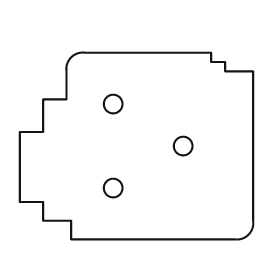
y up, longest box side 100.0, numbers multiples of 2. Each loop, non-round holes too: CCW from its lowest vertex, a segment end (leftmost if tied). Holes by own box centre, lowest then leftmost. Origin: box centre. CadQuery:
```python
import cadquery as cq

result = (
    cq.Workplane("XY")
    .moveTo(-28.0, -40.0)
    .lineTo(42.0, -40.0)
    .threePointArc((48.0, -38.0), (50.0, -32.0))
    .lineTo(50.0, 32.0)
    .lineTo(38.0, 32.0)
    .lineTo(38.0, 36.0)
    .lineTo(32.0, 36.0)
    .lineTo(32.0, 40.0)
    .lineTo(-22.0, 40.0)
    .threePointArc((-28.0, 38.0), (-30.0, 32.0))
    .lineTo(-30.0, 20.0)
    .lineTo(-40.0, 20.0)
    .lineTo(-40.0, 6.0)
    .lineTo(-50.0, 6.0)
    .lineTo(-50.0, -24.0)
    .lineTo(-40.0, -24.0)
    .lineTo(-40.0, -32.0)
    .lineTo(-28.0, -32.0)
    .close()
    .moveTo(-10.0, -18.0)
    .circle(4.0)
    .moveTo(20.0, 0.0)
    .circle(4.0)
    .moveTo(-10.0, 18.0)
    .circle(4.0)
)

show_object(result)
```